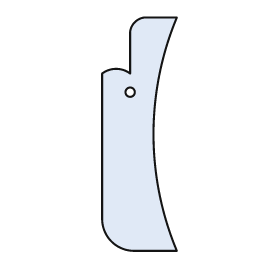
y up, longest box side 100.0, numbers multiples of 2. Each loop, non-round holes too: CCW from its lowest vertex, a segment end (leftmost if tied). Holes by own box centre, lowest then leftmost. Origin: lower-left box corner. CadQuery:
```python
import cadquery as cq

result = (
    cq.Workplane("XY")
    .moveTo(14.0, 0.0)
    .lineTo(32.0, 0.0)
    .threePointArc((22.0, 50.0), (32.0, 100.0))
    .lineTo(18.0, 100.0)
    .threePointArc((14.0, 98.0), (12.0, 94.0))
    .lineTo(12.0, 76.0)
    .threePointArc((6.0, 78.0), (0.0, 76.0))
    .lineTo(0.0, 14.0)
    .threePointArc((4.0, 4.0), (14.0, 0.0))
    .close()
    .moveTo(12.0, 68.0)
    .circle(2.0)
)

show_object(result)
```